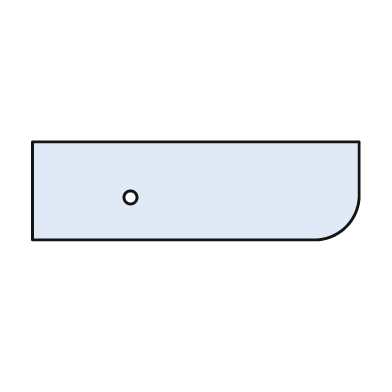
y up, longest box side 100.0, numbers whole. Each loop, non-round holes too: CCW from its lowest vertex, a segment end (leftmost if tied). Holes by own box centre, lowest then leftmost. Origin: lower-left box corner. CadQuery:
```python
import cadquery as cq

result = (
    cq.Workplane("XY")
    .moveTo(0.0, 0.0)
    .lineTo(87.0, 0.0)
    .threePointArc((96.0, 4.0), (100.0, 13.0))
    .lineTo(100.0, 30.0)
    .lineTo(0.0, 30.0)
    .close()
    .moveTo(30.0, 13.0)
    .circle(2.0)
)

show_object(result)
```